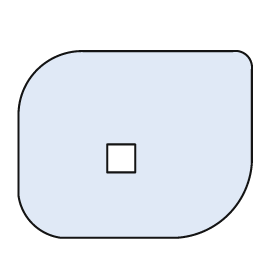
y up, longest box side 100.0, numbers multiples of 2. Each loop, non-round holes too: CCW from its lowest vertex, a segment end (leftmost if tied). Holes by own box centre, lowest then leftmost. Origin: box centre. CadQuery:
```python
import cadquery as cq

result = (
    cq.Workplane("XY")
    .moveTo(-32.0, -40.0)
    .lineTo(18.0, -40.0)
    .threePointArc((40.0, -30.0), (50.0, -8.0))
    .lineTo(50.0, 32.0)
    .threePointArc((48.0, 38.0), (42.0, 40.0))
    .lineTo(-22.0, 40.0)
    .threePointArc((-42.0, 32.0), (-50.0, 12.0))
    .lineTo(-50.0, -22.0)
    .threePointArc((-44.0, -34.0), (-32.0, -40.0))
    .close()
    .moveTo(-12.0, -12.0)
    .lineTo(0.0, -12.0)
    .lineTo(0.0, 0.0)
    .lineTo(-12.0, 0.0)
    .close()
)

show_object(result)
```